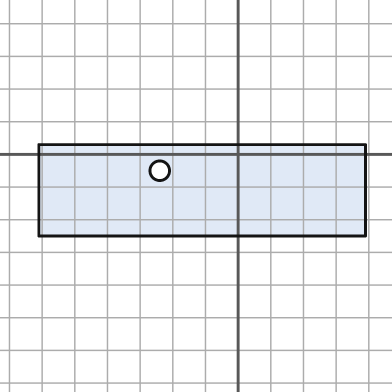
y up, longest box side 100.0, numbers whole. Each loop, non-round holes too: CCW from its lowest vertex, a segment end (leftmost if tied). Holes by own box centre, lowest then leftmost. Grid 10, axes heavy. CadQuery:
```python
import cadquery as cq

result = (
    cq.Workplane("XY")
    .moveTo(-61.0, -25.0)
    .lineTo(39.0, -25.0)
    .lineTo(39.0, 3.0)
    .lineTo(-61.0, 3.0)
    .close()
    .moveTo(-24.0, -5.0)
    .circle(3.0)
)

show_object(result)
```